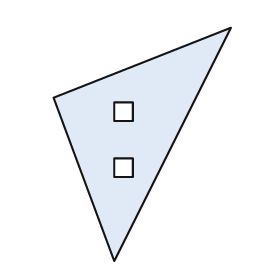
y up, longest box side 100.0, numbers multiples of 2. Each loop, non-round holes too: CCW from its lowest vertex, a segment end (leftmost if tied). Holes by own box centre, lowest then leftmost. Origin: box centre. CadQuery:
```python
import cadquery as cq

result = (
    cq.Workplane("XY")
    .moveTo(-12.0, -50.0)
    .lineTo(38.0, 50.0)
    .lineTo(-38.0, 20.0)
    .close()
    .moveTo(-12.0, -14.0)
    .lineTo(-4.0, -14.0)
    .lineTo(-4.0, -6.0)
    .lineTo(-12.0, -6.0)
    .close()
    .moveTo(-12.0, 10.0)
    .lineTo(-4.0, 10.0)
    .lineTo(-4.0, 18.0)
    .lineTo(-12.0, 18.0)
    .close()
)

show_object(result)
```